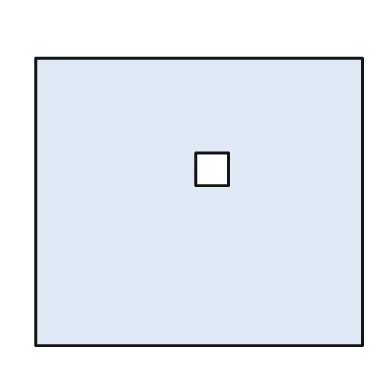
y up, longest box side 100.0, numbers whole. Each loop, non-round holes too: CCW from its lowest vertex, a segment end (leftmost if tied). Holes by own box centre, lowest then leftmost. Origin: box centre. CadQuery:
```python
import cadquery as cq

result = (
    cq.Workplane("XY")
    .moveTo(-50.0, -44.0)
    .lineTo(50.0, -44.0)
    .lineTo(50.0, 44.0)
    .lineTo(-50.0, 44.0)
    .close()
    .moveTo(-1.0, 5.0)
    .lineTo(9.0, 5.0)
    .lineTo(9.0, 15.0)
    .lineTo(-1.0, 15.0)
    .close()
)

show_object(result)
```